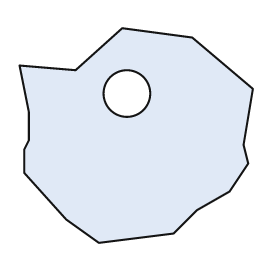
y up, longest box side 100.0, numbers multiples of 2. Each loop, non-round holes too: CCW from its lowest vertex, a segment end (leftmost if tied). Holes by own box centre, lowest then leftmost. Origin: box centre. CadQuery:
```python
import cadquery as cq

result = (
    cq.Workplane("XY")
    .moveTo(-16.0, -46.0)
    .lineTo(16.0, -42.0)
    .lineTo(26.0, -32.0)
    .lineTo(40.0, -24.0)
    .lineTo(48.0, -12.0)
    .lineTo(46.0, -4.0)
    .lineTo(50.0, 20.0)
    .lineTo(24.0, 42.0)
    .lineTo(-6.0, 46.0)
    .lineTo(-26.0, 28.0)
    .lineTo(-50.0, 30.0)
    .lineTo(-46.0, 10.0)
    .lineTo(-46.0, -2.0)
    .lineTo(-48.0, -6.0)
    .lineTo(-48.0, -16.0)
    .lineTo(-30.0, -36.0)
    .close()
    .moveTo(-4.0, 18.0)
    .circle(10.0)
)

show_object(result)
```